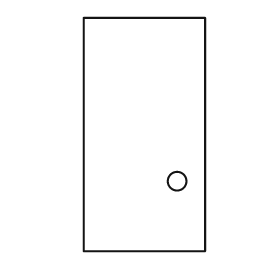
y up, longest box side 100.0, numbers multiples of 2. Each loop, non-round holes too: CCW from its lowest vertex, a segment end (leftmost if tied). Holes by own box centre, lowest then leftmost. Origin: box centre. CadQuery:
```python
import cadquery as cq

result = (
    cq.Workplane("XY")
    .moveTo(-26.0, -50.0)
    .lineTo(26.0, -50.0)
    .lineTo(26.0, 50.0)
    .lineTo(-26.0, 50.0)
    .close()
    .moveTo(14.0, -20.0)
    .circle(4.0)
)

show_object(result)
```